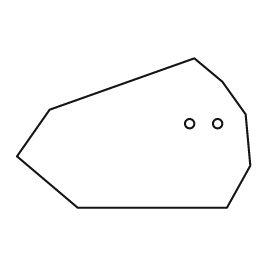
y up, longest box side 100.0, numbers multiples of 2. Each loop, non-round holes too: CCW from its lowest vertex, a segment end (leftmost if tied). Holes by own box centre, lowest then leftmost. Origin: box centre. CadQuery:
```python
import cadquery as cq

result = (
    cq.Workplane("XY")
    .moveTo(-24.0, -32.0)
    .lineTo(40.0, -32.0)
    .lineTo(50.0, -14.0)
    .lineTo(48.0, 8.0)
    .lineTo(38.0, 22.0)
    .lineTo(26.0, 32.0)
    .lineTo(-36.0, 10.0)
    .lineTo(-50.0, -10.0)
    .close()
    .moveTo(24.0, 4.0)
    .circle(2.0)
    .moveTo(36.0, 4.0)
    .circle(2.0)
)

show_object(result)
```